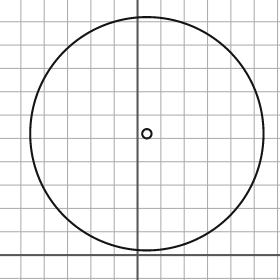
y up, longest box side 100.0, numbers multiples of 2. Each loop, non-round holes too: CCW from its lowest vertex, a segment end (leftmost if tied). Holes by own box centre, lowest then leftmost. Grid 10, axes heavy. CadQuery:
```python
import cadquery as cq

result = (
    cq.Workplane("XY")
    .moveTo(4.0, 52.0)
    .circle(50.0)
    .moveTo(4.0, 52.0)
    .circle(2.0)
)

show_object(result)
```